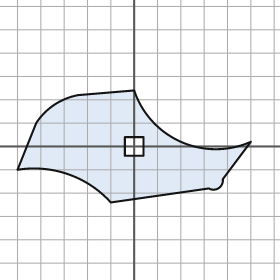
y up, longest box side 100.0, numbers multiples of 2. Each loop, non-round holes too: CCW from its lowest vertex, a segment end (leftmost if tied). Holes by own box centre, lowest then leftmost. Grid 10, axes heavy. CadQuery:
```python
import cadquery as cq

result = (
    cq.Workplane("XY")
    .moveTo(-10.0, -24.0)
    .lineTo(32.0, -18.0)
    .threePointArc((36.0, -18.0), (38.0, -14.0))
    .lineTo(50.0, 2.0)
    .threePointArc((20.0, 2.0), (0.0, 24.0))
    .lineTo(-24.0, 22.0)
    .threePointArc((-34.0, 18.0), (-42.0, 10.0))
    .lineTo(-50.0, -10.0)
    .threePointArc((-28.0, -12.0), (-10.0, -24.0))
    .close()
    .moveTo(-4.0, -4.0)
    .lineTo(4.0, -4.0)
    .lineTo(4.0, 4.0)
    .lineTo(-4.0, 4.0)
    .close()
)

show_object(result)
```